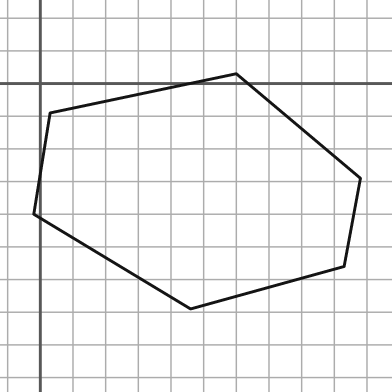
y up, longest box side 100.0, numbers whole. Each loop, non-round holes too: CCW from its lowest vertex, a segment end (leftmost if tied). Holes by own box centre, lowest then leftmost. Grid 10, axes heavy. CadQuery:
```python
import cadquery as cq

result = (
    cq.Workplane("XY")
    .moveTo(46.0, -69.0)
    .lineTo(93.0, -56.0)
    .lineTo(98.0, -29.0)
    .lineTo(60.0, 3.0)
    .lineTo(3.0, -9.0)
    .lineTo(-2.0, -40.0)
    .close()
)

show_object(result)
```